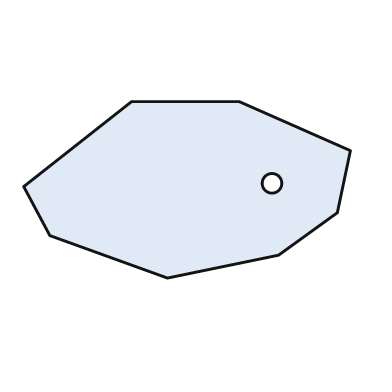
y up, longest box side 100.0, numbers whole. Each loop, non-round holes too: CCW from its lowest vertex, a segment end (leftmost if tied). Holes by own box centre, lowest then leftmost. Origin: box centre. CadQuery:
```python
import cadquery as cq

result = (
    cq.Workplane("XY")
    .moveTo(-6.0, -27.0)
    .lineTo(28.0, -20.0)
    .lineTo(46.0, -7.0)
    .lineTo(50.0, 12.0)
    .lineTo(16.0, 27.0)
    .lineTo(-17.0, 27.0)
    .lineTo(-50.0, 1.0)
    .lineTo(-42.0, -14.0)
    .close()
    .moveTo(26.0, 2.0)
    .circle(3.0)
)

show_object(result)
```